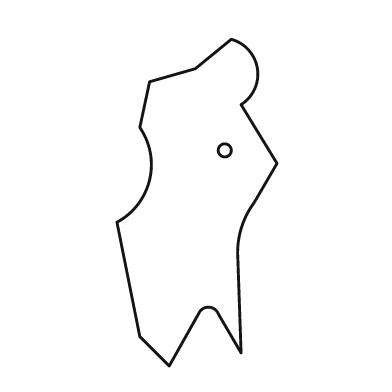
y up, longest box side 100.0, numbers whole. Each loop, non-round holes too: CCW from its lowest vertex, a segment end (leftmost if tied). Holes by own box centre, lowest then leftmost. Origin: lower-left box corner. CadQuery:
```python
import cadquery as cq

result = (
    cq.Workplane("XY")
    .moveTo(16.0, 0.0)
    .lineTo(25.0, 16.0)
    .threePointArc((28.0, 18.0), (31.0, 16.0))
    .lineTo(38.0, 4.0)
    .lineTo(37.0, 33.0)
    .threePointArc((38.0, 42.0), (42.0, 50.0))
    .lineTo(49.0, 62.0)
    .lineTo(38.0, 80.0)
    .threePointArc((43.0, 91.0), (35.0, 100.0))
    .lineTo(24.0, 91.0)
    .lineTo(10.0, 87.0)
    .lineTo(7.0, 73.0)
    .threePointArc((10.0, 57.0), (0.0, 44.0))
    .lineTo(7.0, 9.0)
    .close()
    .moveTo(33.0, 66.0)
    .circle(2.0)
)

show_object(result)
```